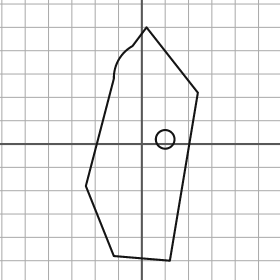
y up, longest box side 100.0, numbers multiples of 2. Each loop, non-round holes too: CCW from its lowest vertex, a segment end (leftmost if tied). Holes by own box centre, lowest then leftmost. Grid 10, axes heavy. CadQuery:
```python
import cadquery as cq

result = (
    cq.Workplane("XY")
    .moveTo(12.0, -50.0)
    .lineTo(24.0, 22.0)
    .lineTo(2.0, 50.0)
    .lineTo(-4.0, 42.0)
    .threePointArc((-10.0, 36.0), (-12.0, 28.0))
    .lineTo(-24.0, -18.0)
    .lineTo(-12.0, -48.0)
    .close()
    .moveTo(10.0, 2.0)
    .circle(4.0)
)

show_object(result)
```